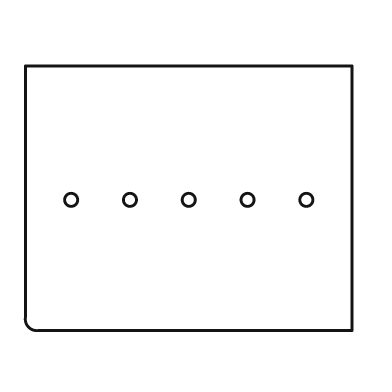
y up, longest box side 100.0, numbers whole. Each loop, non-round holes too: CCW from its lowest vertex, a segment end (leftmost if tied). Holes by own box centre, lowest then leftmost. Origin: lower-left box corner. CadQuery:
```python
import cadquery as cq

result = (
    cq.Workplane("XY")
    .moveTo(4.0, 0.0)
    .lineTo(100.0, 0.0)
    .lineTo(100.0, 81.0)
    .lineTo(0.0, 81.0)
    .lineTo(0.0, 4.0)
    .threePointArc((1.0, 1.0), (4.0, 0.0))
    .close()
    .moveTo(14.0, 40.0)
    .circle(2.0)
    .moveTo(32.0, 40.0)
    .circle(2.0)
    .moveTo(50.0, 40.0)
    .circle(2.0)
    .moveTo(68.0, 40.0)
    .circle(2.0)
    .moveTo(86.0, 40.0)
    .circle(2.0)
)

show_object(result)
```